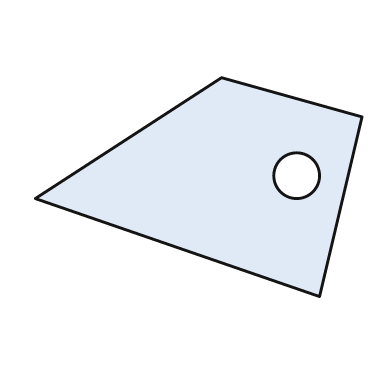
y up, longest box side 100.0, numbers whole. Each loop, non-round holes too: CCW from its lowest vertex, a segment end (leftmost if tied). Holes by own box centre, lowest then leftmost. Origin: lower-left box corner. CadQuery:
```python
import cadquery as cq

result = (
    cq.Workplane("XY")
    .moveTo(87.0, 0.0)
    .lineTo(100.0, 55.0)
    .lineTo(57.0, 67.0)
    .lineTo(0.0, 30.0)
    .close()
    .moveTo(80.0, 37.0)
    .circle(7.0)
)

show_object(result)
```